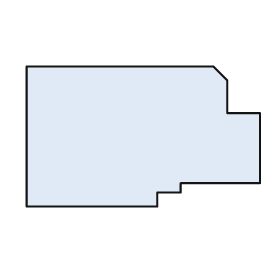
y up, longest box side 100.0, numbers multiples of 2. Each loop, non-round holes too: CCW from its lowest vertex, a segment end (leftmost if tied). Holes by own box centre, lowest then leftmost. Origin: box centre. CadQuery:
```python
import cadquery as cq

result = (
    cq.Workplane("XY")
    .moveTo(-50.0, -30.0)
    .lineTo(6.0, -30.0)
    .lineTo(6.0, -24.0)
    .lineTo(16.0, -24.0)
    .lineTo(16.0, -20.0)
    .lineTo(50.0, -20.0)
    .lineTo(50.0, 10.0)
    .lineTo(36.0, 10.0)
    .lineTo(36.0, 24.0)
    .lineTo(30.0, 30.0)
    .lineTo(-50.0, 30.0)
    .close()
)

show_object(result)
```